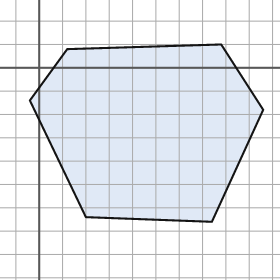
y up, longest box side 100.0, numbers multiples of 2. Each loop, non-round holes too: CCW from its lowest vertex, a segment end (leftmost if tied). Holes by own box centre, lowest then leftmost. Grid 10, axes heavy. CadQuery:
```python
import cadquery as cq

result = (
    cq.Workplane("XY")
    .moveTo(74.0, -66.0)
    .lineTo(96.0, -18.0)
    .lineTo(78.0, 10.0)
    .lineTo(12.0, 8.0)
    .lineTo(-4.0, -14.0)
    .lineTo(20.0, -64.0)
    .close()
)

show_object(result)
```